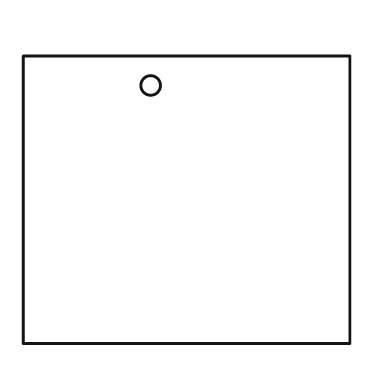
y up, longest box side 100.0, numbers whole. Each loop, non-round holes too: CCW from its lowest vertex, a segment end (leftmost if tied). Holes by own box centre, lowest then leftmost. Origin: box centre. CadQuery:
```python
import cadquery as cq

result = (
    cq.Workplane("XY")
    .moveTo(-50.0, -44.0)
    .lineTo(50.0, -44.0)
    .lineTo(50.0, 44.0)
    .lineTo(-50.0, 44.0)
    .close()
    .moveTo(-11.0, 35.0)
    .circle(3.0)
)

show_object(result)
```